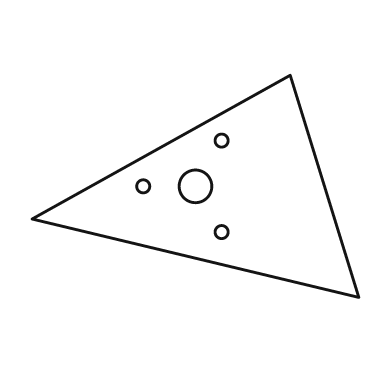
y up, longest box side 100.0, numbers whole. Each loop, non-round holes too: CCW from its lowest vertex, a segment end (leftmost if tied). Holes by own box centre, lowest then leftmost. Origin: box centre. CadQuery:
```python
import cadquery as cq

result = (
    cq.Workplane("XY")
    .moveTo(50.0, -34.0)
    .lineTo(29.0, 34.0)
    .lineTo(-50.0, -10.0)
    .close()
    .moveTo(8.0, -14.0)
    .circle(2.0)
    .moveTo(-16.0, 0.0)
    .circle(2.0)
    .moveTo(0.0, 0.0)
    .circle(5.0)
    .moveTo(8.0, 14.0)
    .circle(2.0)
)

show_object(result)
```